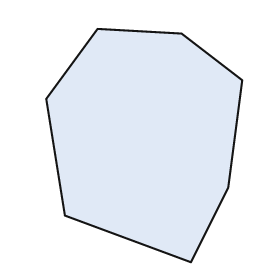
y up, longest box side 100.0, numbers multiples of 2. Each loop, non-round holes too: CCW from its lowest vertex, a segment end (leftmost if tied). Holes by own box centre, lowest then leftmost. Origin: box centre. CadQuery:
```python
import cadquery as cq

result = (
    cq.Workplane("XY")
    .moveTo(20.0, -50.0)
    .lineTo(36.0, -18.0)
    .lineTo(42.0, 28.0)
    .lineTo(16.0, 48.0)
    .lineTo(-20.0, 50.0)
    .lineTo(-42.0, 20.0)
    .lineTo(-34.0, -30.0)
    .close()
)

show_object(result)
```